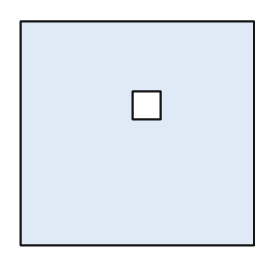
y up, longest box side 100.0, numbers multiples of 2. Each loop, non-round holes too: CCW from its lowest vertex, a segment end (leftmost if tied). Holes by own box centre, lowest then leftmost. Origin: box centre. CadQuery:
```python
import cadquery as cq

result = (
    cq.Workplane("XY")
    .moveTo(-50.0, -48.0)
    .lineTo(50.0, -48.0)
    .lineTo(50.0, 48.0)
    .lineTo(-50.0, 48.0)
    .close()
    .moveTo(-2.0, 6.0)
    .lineTo(10.0, 6.0)
    .lineTo(10.0, 18.0)
    .lineTo(-2.0, 18.0)
    .close()
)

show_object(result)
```